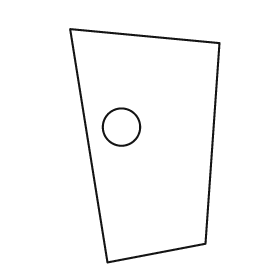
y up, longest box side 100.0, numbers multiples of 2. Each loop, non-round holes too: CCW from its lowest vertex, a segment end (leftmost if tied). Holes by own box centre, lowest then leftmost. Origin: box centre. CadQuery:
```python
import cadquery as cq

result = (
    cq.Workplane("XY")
    .moveTo(-16.0, -50.0)
    .lineTo(26.0, -42.0)
    .lineTo(32.0, 44.0)
    .lineTo(-32.0, 50.0)
    .close()
    .moveTo(-10.0, 8.0)
    .circle(8.0)
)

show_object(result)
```